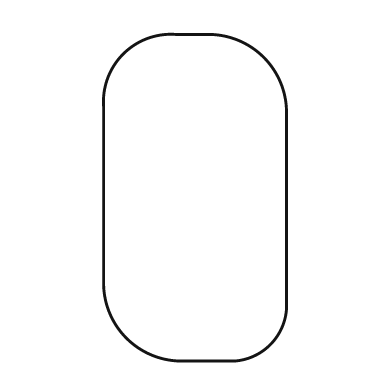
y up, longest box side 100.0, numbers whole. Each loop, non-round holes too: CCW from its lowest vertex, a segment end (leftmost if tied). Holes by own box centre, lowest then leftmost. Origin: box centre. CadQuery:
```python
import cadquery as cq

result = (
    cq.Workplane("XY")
    .moveTo(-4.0, -50.0)
    .lineTo(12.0, -50.0)
    .threePointArc((23.0, -45.0), (28.0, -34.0))
    .lineTo(28.0, 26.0)
    .threePointArc((21.0, 43.0), (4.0, 50.0))
    .lineTo(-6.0, 50.0)
    .threePointArc((-22.0, 44.0), (-28.0, 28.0))
    .lineTo(-28.0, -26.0)
    .threePointArc((-21.0, -43.0), (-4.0, -50.0))
    .close()
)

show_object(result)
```